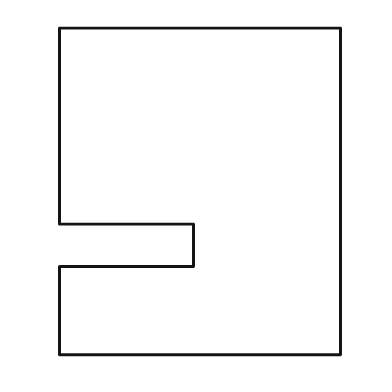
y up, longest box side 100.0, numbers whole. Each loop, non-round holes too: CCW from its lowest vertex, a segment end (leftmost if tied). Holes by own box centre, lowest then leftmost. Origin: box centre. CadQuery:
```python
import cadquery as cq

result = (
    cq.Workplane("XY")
    .moveTo(-43.0, -50.0)
    .lineTo(43.0, -50.0)
    .lineTo(43.0, 50.0)
    .lineTo(-43.0, 50.0)
    .lineTo(-43.0, -10.0)
    .lineTo(-2.0, -10.0)
    .lineTo(-2.0, -23.0)
    .lineTo(-43.0, -23.0)
    .close()
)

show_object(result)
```